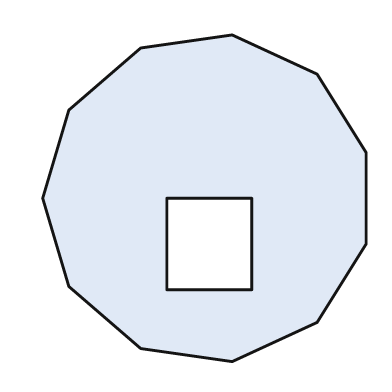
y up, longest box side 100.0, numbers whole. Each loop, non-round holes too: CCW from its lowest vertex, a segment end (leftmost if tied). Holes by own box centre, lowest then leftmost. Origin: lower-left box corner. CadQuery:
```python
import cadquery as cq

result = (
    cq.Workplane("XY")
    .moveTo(58.0, 0.0)
    .lineTo(84.0, 12.0)
    .lineTo(99.0, 36.0)
    .lineTo(99.0, 64.0)
    .lineTo(84.0, 88.0)
    .lineTo(58.0, 100.0)
    .lineTo(30.0, 96.0)
    .lineTo(8.0, 77.0)
    .lineTo(0.0, 50.0)
    .lineTo(8.0, 23.0)
    .lineTo(30.0, 4.0)
    .close()
    .moveTo(38.0, 22.0)
    .lineTo(64.0, 22.0)
    .lineTo(64.0, 50.0)
    .lineTo(38.0, 50.0)
    .close()
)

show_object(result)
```